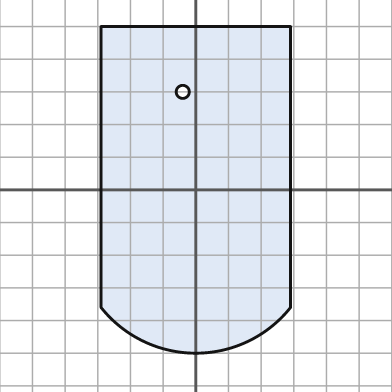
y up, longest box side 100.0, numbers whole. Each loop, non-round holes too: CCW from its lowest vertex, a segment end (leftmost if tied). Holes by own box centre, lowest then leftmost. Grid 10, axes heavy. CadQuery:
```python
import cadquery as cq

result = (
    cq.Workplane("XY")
    .moveTo(-29.0, -36.0)
    .threePointArc((0.0, -50.0), (29.0, -36.0))
    .lineTo(29.0, 50.0)
    .lineTo(-29.0, 50.0)
    .close()
    .moveTo(-4.0, 30.0)
    .circle(2.0)
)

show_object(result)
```